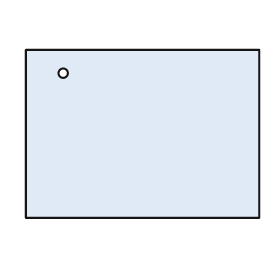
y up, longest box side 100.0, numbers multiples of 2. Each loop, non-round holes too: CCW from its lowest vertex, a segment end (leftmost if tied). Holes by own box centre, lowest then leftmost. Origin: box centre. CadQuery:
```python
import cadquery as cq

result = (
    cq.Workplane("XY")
    .moveTo(-50.0, -36.0)
    .lineTo(50.0, -36.0)
    .lineTo(50.0, 36.0)
    .lineTo(-50.0, 36.0)
    .close()
    .moveTo(-34.0, 26.0)
    .circle(2.0)
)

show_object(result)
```